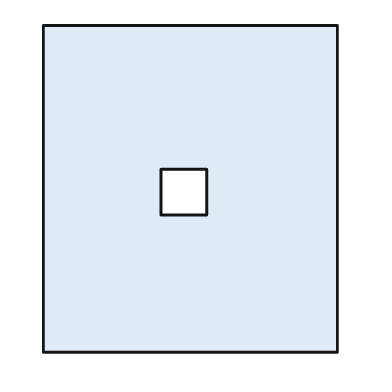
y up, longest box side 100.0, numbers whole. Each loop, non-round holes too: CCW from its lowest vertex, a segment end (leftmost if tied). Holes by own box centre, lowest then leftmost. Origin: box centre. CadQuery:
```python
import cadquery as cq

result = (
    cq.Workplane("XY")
    .moveTo(-45.0, -50.0)
    .lineTo(45.0, -50.0)
    .lineTo(45.0, 50.0)
    .lineTo(-45.0, 50.0)
    .close()
    .moveTo(-9.0, -8.0)
    .lineTo(5.0, -8.0)
    .lineTo(5.0, 6.0)
    .lineTo(-9.0, 6.0)
    .close()
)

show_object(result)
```